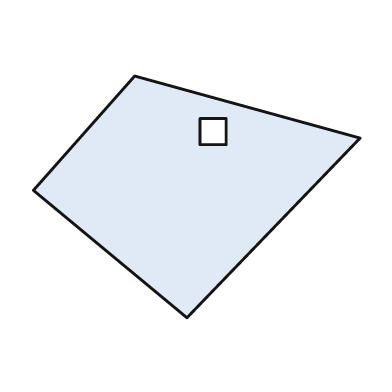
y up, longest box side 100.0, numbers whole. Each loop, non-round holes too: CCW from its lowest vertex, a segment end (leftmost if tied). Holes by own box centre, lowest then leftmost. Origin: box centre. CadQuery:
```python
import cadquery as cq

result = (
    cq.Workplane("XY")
    .moveTo(-3.0, -37.0)
    .lineTo(50.0, 18.0)
    .lineTo(-19.0, 37.0)
    .lineTo(-50.0, 2.0)
    .close()
    .moveTo(1.0, 16.0)
    .lineTo(9.0, 16.0)
    .lineTo(9.0, 24.0)
    .lineTo(1.0, 24.0)
    .close()
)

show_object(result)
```